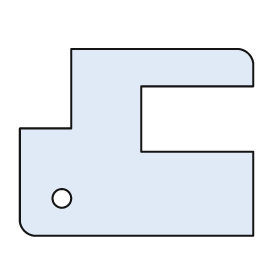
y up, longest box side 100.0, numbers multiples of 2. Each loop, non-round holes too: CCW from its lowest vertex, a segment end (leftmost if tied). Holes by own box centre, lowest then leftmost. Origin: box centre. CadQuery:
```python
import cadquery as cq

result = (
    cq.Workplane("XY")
    .moveTo(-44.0, -40.0)
    .lineTo(50.0, -40.0)
    .lineTo(50.0, -4.0)
    .lineTo(2.0, -4.0)
    .lineTo(2.0, 24.0)
    .lineTo(50.0, 24.0)
    .lineTo(50.0, 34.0)
    .threePointArc((48.0, 38.0), (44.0, 40.0))
    .lineTo(-28.0, 40.0)
    .lineTo(-28.0, 6.0)
    .lineTo(-50.0, 6.0)
    .lineTo(-50.0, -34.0)
    .threePointArc((-48.0, -38.0), (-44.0, -40.0))
    .close()
    .moveTo(-32.0, -24.0)
    .circle(4.0)
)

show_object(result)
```